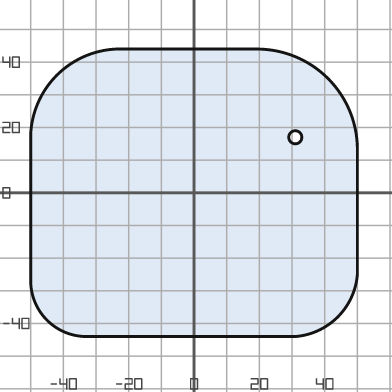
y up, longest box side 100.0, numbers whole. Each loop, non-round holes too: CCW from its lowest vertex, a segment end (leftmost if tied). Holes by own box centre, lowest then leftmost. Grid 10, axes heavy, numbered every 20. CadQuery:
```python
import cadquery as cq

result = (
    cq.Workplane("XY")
    .moveTo(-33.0, -44.0)
    .lineTo(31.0, -44.0)
    .threePointArc((44.0, -38.0), (50.0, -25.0))
    .lineTo(50.0, 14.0)
    .threePointArc((41.0, 35.0), (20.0, 44.0))
    .lineTo(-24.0, 44.0)
    .threePointArc((-42.0, 36.0), (-50.0, 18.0))
    .lineTo(-50.0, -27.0)
    .threePointArc((-45.0, -39.0), (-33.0, -44.0))
    .close()
    .moveTo(31.0, 17.0)
    .circle(2.0)
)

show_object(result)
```